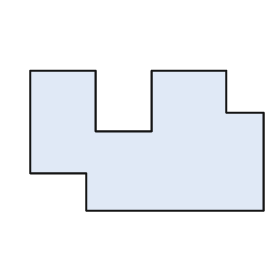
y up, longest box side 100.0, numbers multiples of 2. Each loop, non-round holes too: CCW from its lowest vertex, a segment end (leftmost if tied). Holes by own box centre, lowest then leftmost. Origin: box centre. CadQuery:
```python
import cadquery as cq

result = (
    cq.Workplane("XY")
    .moveTo(-26.0, -30.0)
    .lineTo(50.0, -30.0)
    .lineTo(50.0, 12.0)
    .lineTo(34.0, 12.0)
    .lineTo(34.0, 30.0)
    .lineTo(2.0, 30.0)
    .lineTo(2.0, 4.0)
    .lineTo(-22.0, 4.0)
    .lineTo(-22.0, 30.0)
    .lineTo(-50.0, 30.0)
    .lineTo(-50.0, -14.0)
    .lineTo(-26.0, -14.0)
    .close()
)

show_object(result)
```